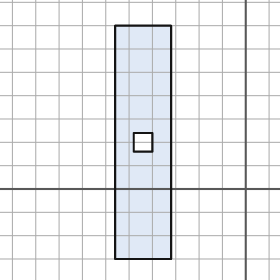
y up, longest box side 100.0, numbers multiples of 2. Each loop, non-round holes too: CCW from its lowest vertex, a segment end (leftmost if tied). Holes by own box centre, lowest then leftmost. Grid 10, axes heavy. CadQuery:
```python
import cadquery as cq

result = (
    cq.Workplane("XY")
    .moveTo(-56.0, -30.0)
    .lineTo(-32.0, -30.0)
    .lineTo(-32.0, 70.0)
    .lineTo(-56.0, 70.0)
    .close()
    .moveTo(-48.0, 16.0)
    .lineTo(-40.0, 16.0)
    .lineTo(-40.0, 24.0)
    .lineTo(-48.0, 24.0)
    .close()
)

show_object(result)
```